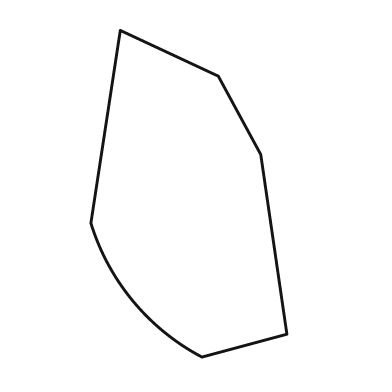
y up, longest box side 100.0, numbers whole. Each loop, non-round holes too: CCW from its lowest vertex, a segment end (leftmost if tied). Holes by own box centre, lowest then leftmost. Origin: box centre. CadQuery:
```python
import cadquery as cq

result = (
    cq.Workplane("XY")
    .moveTo(4.0, -50.0)
    .lineTo(30.0, -43.0)
    .lineTo(22.0, 12.0)
    .lineTo(9.0, 36.0)
    .lineTo(-21.0, 50.0)
    .lineTo(-30.0, -9.0)
    .threePointArc((-17.0, -33.0), (4.0, -50.0))
    .close()
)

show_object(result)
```